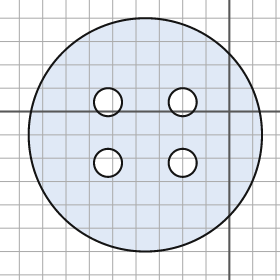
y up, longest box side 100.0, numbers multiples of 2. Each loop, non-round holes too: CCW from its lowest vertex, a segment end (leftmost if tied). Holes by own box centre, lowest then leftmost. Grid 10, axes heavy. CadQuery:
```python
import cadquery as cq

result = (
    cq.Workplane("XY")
    .moveTo(-36.0, -10.0)
    .circle(50.0)
    .moveTo(-52.0, -22.0)
    .circle(6.0)
    .moveTo(-20.0, -22.0)
    .circle(6.0)
    .moveTo(-52.0, 4.0)
    .circle(6.0)
    .moveTo(-20.0, 4.0)
    .circle(6.0)
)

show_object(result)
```